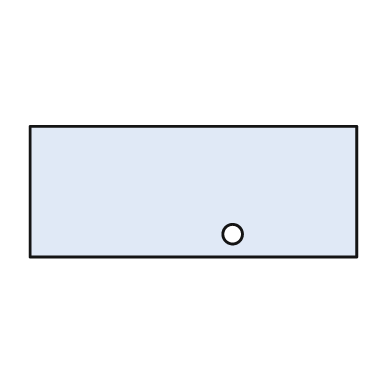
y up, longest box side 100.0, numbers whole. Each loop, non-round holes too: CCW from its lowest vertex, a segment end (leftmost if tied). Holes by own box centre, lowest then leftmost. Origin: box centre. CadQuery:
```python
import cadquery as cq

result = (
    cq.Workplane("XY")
    .moveTo(-50.0, -20.0)
    .lineTo(50.0, -20.0)
    .lineTo(50.0, 20.0)
    .lineTo(-50.0, 20.0)
    .close()
    .moveTo(12.0, -13.0)
    .circle(3.0)
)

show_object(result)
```